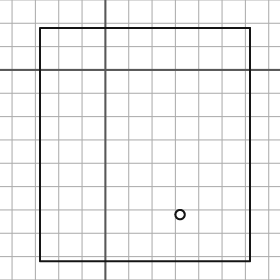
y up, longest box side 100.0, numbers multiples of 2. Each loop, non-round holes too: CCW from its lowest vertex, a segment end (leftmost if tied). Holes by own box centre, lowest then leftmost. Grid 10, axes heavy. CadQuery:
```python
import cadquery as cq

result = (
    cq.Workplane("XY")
    .moveTo(-28.0, -82.0)
    .lineTo(62.0, -82.0)
    .lineTo(62.0, 18.0)
    .lineTo(-28.0, 18.0)
    .close()
    .moveTo(32.0, -62.0)
    .circle(2.0)
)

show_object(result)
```